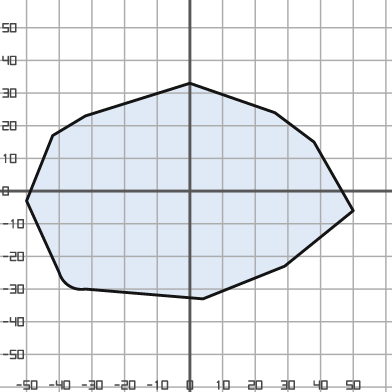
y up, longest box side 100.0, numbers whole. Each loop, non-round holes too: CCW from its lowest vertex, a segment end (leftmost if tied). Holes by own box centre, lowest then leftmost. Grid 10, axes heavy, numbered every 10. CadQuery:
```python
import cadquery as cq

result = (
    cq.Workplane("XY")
    .moveTo(4.0, -33.0)
    .lineTo(29.0, -23.0)
    .lineTo(50.0, -6.0)
    .lineTo(38.0, 15.0)
    .lineTo(26.0, 24.0)
    .lineTo(0.0, 33.0)
    .lineTo(-32.0, 23.0)
    .lineTo(-42.0, 17.0)
    .lineTo(-50.0, -3.0)
    .lineTo(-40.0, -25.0)
    .threePointArc((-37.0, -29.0), (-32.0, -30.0))
    .close()
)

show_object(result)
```